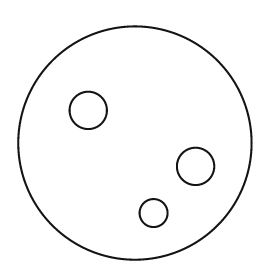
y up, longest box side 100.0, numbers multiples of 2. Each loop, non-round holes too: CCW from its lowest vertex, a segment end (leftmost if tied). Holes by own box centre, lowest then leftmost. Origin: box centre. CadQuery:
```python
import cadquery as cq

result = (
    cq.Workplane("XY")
    .moveTo(0.0, 0.0)
    .circle(50.0)
    .moveTo(8.0, -30.0)
    .circle(6.0)
    .moveTo(26.0, -10.0)
    .circle(8.0)
    .moveTo(-20.0, 14.0)
    .circle(8.0)
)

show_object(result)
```